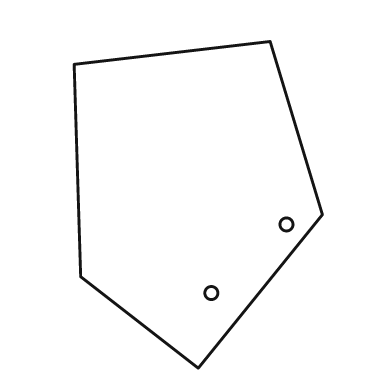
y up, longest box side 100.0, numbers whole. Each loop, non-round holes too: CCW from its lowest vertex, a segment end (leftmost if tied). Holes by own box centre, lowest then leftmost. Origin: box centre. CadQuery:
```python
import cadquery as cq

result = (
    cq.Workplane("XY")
    .moveTo(0.0, -50.0)
    .lineTo(38.0, -3.0)
    .lineTo(22.0, 50.0)
    .lineTo(-38.0, 43.0)
    .lineTo(-36.0, -22.0)
    .close()
    .moveTo(4.0, -27.0)
    .circle(2.0)
    .moveTo(27.0, -6.0)
    .circle(2.0)
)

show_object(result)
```